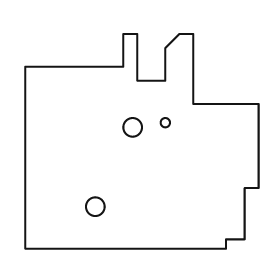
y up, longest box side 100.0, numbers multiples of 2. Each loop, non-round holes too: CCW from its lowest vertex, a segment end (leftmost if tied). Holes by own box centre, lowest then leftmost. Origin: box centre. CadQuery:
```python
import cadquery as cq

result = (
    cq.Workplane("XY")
    .moveTo(-50.0, -46.0)
    .lineTo(36.0, -46.0)
    .lineTo(36.0, -42.0)
    .lineTo(44.0, -42.0)
    .lineTo(44.0, -20.0)
    .lineTo(50.0, -20.0)
    .lineTo(50.0, 16.0)
    .lineTo(22.0, 16.0)
    .lineTo(22.0, 46.0)
    .lineTo(16.0, 46.0)
    .lineTo(10.0, 40.0)
    .lineTo(10.0, 26.0)
    .lineTo(-2.0, 26.0)
    .lineTo(-2.0, 46.0)
    .lineTo(-8.0, 46.0)
    .lineTo(-8.0, 32.0)
    .lineTo(-50.0, 32.0)
    .close()
    .moveTo(-20.0, -28.0)
    .circle(4.0)
    .moveTo(-4.0, 6.0)
    .circle(4.0)
    .moveTo(10.0, 8.0)
    .circle(2.0)
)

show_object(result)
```